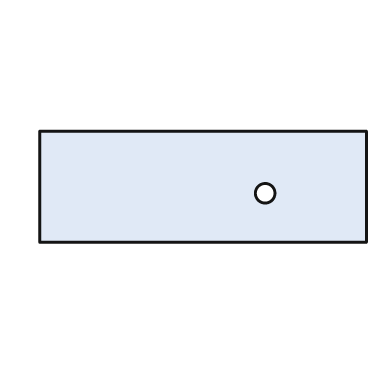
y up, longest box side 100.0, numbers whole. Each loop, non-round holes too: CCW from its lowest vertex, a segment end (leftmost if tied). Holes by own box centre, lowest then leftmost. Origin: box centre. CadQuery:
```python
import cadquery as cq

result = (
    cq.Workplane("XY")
    .moveTo(-50.0, -17.0)
    .lineTo(50.0, -17.0)
    .lineTo(50.0, 17.0)
    .lineTo(-50.0, 17.0)
    .close()
    .moveTo(19.0, -2.0)
    .circle(3.0)
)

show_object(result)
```